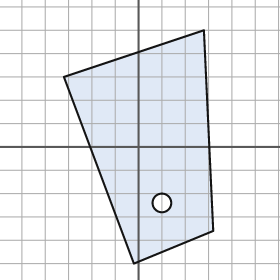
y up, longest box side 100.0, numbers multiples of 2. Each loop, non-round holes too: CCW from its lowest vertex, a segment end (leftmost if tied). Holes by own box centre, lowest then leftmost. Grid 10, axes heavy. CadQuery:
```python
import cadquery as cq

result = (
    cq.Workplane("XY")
    .moveTo(-2.0, -50.0)
    .lineTo(32.0, -36.0)
    .lineTo(28.0, 50.0)
    .lineTo(-32.0, 30.0)
    .close()
    .moveTo(10.0, -24.0)
    .circle(4.0)
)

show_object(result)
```